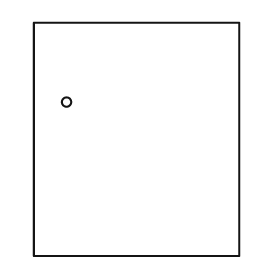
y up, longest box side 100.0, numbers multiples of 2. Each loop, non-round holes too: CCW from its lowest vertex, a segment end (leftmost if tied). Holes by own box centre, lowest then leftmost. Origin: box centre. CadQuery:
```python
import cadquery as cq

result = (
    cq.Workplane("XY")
    .moveTo(-44.0, -50.0)
    .lineTo(44.0, -50.0)
    .lineTo(44.0, 50.0)
    .lineTo(-44.0, 50.0)
    .close()
    .moveTo(-30.0, 16.0)
    .circle(2.0)
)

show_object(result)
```